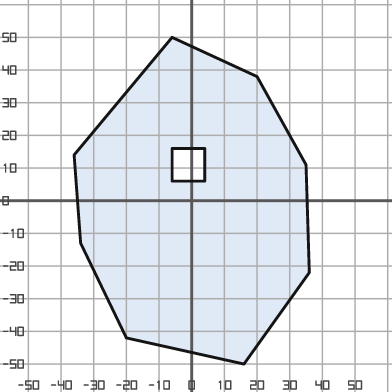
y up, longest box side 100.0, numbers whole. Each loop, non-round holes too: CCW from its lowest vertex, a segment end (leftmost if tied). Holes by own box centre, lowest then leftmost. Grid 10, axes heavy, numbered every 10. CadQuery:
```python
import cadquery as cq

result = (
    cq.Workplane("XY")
    .moveTo(16.0, -50.0)
    .lineTo(36.0, -22.0)
    .lineTo(35.0, 11.0)
    .lineTo(20.0, 38.0)
    .lineTo(-6.0, 50.0)
    .lineTo(-36.0, 14.0)
    .lineTo(-34.0, -13.0)
    .lineTo(-20.0, -42.0)
    .close()
    .moveTo(-6.0, 6.0)
    .lineTo(4.0, 6.0)
    .lineTo(4.0, 16.0)
    .lineTo(-6.0, 16.0)
    .close()
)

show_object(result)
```